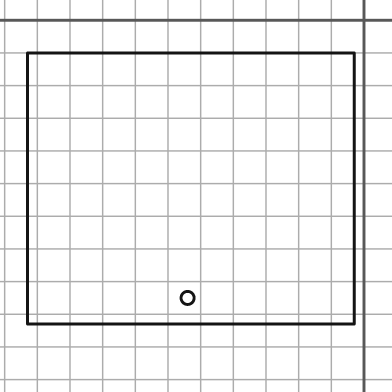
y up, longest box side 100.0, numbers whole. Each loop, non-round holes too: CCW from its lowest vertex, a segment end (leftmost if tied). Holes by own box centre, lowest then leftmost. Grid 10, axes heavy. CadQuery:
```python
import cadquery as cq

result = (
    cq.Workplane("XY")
    .moveTo(-103.0, -93.0)
    .lineTo(-3.0, -93.0)
    .lineTo(-3.0, -10.0)
    .lineTo(-103.0, -10.0)
    .close()
    .moveTo(-54.0, -85.0)
    .circle(2.0)
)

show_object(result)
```